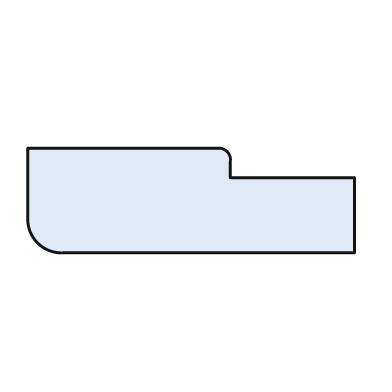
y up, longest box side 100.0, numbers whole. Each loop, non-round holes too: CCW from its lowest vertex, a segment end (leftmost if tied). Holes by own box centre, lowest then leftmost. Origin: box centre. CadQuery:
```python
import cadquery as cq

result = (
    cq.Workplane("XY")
    .moveTo(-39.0, -16.0)
    .lineTo(50.0, -16.0)
    .lineTo(50.0, 7.0)
    .lineTo(12.0, 7.0)
    .lineTo(12.0, 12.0)
    .threePointArc((11.0, 15.0), (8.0, 16.0))
    .lineTo(-50.0, 16.0)
    .lineTo(-50.0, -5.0)
    .threePointArc((-47.0, -13.0), (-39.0, -16.0))
    .close()
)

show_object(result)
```